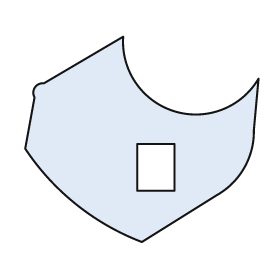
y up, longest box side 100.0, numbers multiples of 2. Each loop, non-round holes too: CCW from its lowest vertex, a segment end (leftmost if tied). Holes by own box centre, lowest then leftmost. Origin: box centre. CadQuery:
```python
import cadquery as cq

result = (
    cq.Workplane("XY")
    .moveTo(0.0, -44.0)
    .lineTo(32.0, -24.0)
    .threePointArc((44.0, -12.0), (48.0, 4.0))
    .lineTo(50.0, 26.0)
    .threePointArc((14.0, 12.0), (-8.0, 44.0))
    .lineTo(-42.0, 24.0)
    .threePointArc((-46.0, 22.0), (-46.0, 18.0))
    .lineTo(-50.0, -4.0)
    .threePointArc((-28.0, -28.0), (0.0, -44.0))
    .close()
    .moveTo(-2.0, -22.0)
    .lineTo(14.0, -22.0)
    .lineTo(14.0, -2.0)
    .lineTo(-2.0, -2.0)
    .close()
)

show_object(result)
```